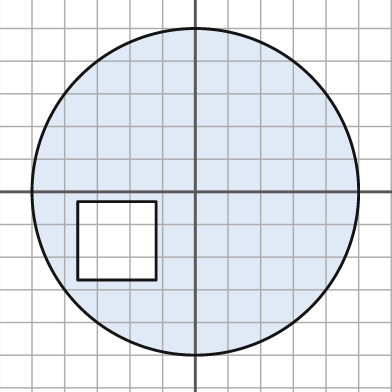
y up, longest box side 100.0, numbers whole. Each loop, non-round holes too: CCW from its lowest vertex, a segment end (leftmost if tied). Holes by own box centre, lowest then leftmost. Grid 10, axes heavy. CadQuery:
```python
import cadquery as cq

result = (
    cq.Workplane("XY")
    .moveTo(0.0, 0.0)
    .circle(50.0)
    .moveTo(-36.0, -27.0)
    .lineTo(-12.0, -27.0)
    .lineTo(-12.0, -3.0)
    .lineTo(-36.0, -3.0)
    .close()
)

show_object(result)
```